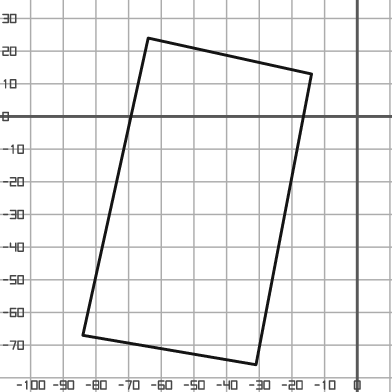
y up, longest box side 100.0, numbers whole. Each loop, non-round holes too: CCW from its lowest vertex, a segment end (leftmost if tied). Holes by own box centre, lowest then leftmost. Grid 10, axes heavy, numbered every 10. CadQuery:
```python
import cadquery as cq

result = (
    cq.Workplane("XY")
    .moveTo(-31.0, -76.0)
    .lineTo(-14.0, 13.0)
    .lineTo(-64.0, 24.0)
    .lineTo(-84.0, -67.0)
    .close()
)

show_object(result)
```